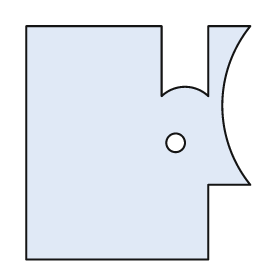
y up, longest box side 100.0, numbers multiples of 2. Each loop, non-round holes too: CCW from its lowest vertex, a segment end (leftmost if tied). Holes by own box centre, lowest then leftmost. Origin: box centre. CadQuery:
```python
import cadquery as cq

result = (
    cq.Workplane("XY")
    .moveTo(-48.0, -50.0)
    .lineTo(30.0, -50.0)
    .lineTo(30.0, -18.0)
    .lineTo(48.0, -18.0)
    .threePointArc((36.0, 16.0), (48.0, 50.0))
    .lineTo(30.0, 50.0)
    .lineTo(30.0, 20.0)
    .threePointArc((20.0, 24.0), (10.0, 20.0))
    .lineTo(10.0, 50.0)
    .lineTo(-48.0, 50.0)
    .close()
    .moveTo(16.0, 0.0)
    .circle(4.0)
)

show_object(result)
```